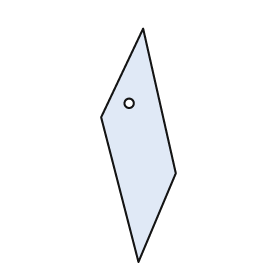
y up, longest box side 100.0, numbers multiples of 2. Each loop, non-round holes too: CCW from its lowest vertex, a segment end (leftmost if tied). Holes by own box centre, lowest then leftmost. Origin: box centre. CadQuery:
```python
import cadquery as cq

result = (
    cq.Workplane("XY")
    .moveTo(0.0, -50.0)
    .lineTo(16.0, -12.0)
    .lineTo(2.0, 50.0)
    .lineTo(-16.0, 12.0)
    .close()
    .moveTo(-4.0, 18.0)
    .circle(2.0)
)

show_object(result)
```